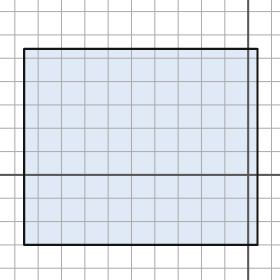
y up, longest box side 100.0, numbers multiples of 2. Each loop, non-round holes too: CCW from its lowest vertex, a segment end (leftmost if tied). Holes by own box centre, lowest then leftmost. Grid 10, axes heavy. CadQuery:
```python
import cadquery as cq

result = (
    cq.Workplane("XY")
    .moveTo(-96.0, -30.0)
    .lineTo(4.0, -30.0)
    .lineTo(4.0, 54.0)
    .lineTo(-96.0, 54.0)
    .close()
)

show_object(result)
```